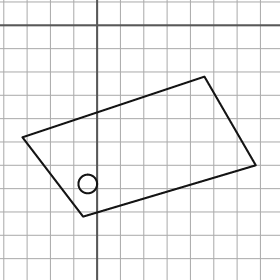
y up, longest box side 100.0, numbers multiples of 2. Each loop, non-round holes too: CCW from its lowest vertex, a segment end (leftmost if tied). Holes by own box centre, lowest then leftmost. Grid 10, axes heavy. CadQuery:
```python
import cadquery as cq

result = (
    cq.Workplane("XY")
    .moveTo(-6.0, -82.0)
    .lineTo(68.0, -60.0)
    .lineTo(46.0, -22.0)
    .lineTo(-32.0, -48.0)
    .close()
    .moveTo(-4.0, -68.0)
    .circle(4.0)
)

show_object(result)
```